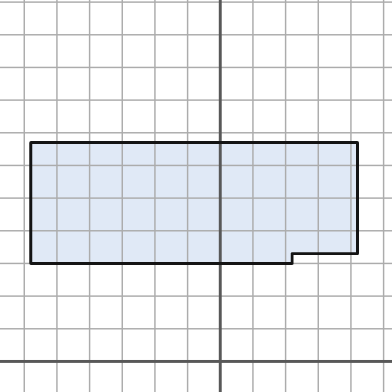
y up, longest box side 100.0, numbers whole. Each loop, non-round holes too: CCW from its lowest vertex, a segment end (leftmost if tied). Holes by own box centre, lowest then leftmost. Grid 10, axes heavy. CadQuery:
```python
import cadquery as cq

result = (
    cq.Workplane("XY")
    .moveTo(-58.0, 30.0)
    .lineTo(22.0, 30.0)
    .lineTo(22.0, 33.0)
    .lineTo(42.0, 33.0)
    .lineTo(42.0, 67.0)
    .lineTo(-58.0, 67.0)
    .close()
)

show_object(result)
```